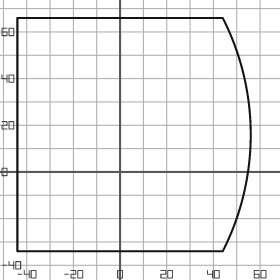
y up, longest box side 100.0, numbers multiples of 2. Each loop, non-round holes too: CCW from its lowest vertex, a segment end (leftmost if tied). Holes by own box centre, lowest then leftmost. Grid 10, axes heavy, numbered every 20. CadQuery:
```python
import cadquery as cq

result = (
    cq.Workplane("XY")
    .moveTo(-44.0, -34.0)
    .lineTo(44.0, -34.0)
    .threePointArc((56.0, 16.0), (44.0, 66.0))
    .lineTo(-44.0, 66.0)
    .close()
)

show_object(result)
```